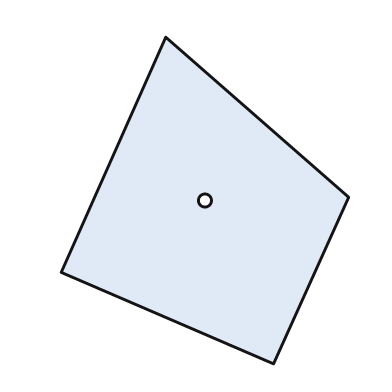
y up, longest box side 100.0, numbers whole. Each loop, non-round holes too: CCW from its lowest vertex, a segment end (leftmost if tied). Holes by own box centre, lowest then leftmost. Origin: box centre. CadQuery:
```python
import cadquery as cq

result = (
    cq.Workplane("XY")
    .moveTo(21.0, -50.0)
    .lineTo(44.0, 1.0)
    .lineTo(-12.0, 50.0)
    .lineTo(-44.0, -22.0)
    .close()
    .moveTo(0.0, 0.0)
    .circle(2.0)
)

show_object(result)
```